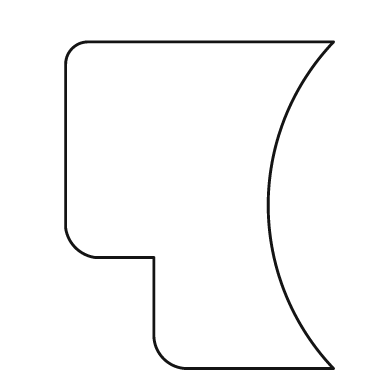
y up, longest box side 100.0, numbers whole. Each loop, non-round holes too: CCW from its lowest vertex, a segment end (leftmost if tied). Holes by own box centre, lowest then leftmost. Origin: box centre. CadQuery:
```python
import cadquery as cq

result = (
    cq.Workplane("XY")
    .moveTo(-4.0, -50.0)
    .lineTo(41.0, -50.0)
    .threePointArc((21.0, 0.0), (41.0, 50.0))
    .lineTo(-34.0, 50.0)
    .threePointArc((-39.0, 48.0), (-41.0, 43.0))
    .lineTo(-41.0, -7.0)
    .threePointArc((-38.0, -13.0), (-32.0, -16.0))
    .lineTo(-14.0, -16.0)
    .lineTo(-14.0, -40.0)
    .threePointArc((-11.0, -47.0), (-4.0, -50.0))
    .close()
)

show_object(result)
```